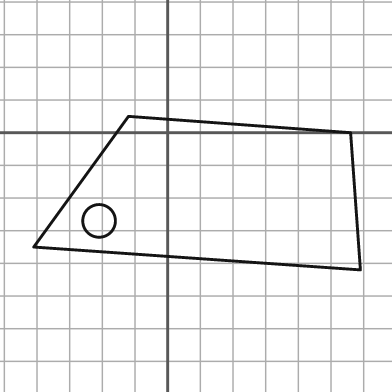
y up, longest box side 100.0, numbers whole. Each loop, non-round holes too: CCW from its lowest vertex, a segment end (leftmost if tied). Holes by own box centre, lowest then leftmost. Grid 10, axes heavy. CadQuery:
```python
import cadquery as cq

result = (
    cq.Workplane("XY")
    .moveTo(59.0, -42.0)
    .lineTo(56.0, 0.0)
    .lineTo(-12.0, 5.0)
    .lineTo(-41.0, -35.0)
    .close()
    .moveTo(-21.0, -27.0)
    .circle(5.0)
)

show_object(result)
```